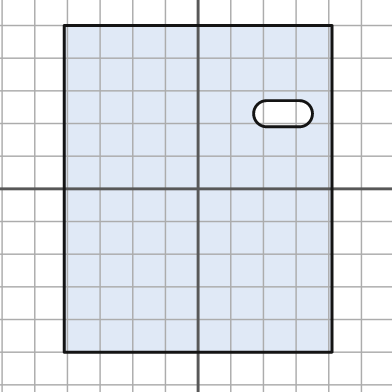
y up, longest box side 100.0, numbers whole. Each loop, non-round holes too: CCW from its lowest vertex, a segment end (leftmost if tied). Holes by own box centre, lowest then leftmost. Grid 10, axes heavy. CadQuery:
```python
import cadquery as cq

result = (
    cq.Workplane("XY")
    .moveTo(-41.0, -50.0)
    .lineTo(41.0, -50.0)
    .lineTo(41.0, 50.0)
    .lineTo(-41.0, 50.0)
    .close()
    .moveTo(21.0, 19.0)
    .lineTo(31.0, 19.0)
    .threePointArc((35.0, 23.0), (31.0, 27.0))
    .lineTo(21.0, 27.0)
    .threePointArc((17.0, 23.0), (21.0, 19.0))
    .close()
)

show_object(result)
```